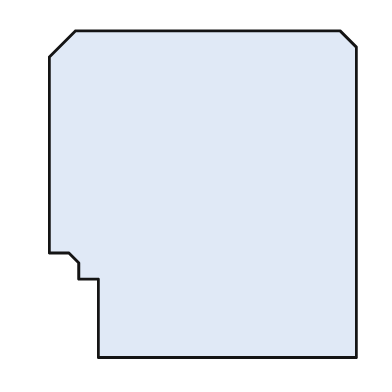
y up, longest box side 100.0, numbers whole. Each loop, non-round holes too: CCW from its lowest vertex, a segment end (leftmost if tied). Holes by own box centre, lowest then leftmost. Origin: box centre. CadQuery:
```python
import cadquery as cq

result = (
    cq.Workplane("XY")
    .moveTo(-32.0, -50.0)
    .lineTo(47.0, -50.0)
    .lineTo(47.0, 45.0)
    .lineTo(42.0, 50.0)
    .lineTo(-39.0, 50.0)
    .lineTo(-47.0, 42.0)
    .lineTo(-47.0, -18.0)
    .lineTo(-41.0, -18.0)
    .lineTo(-38.0, -21.0)
    .lineTo(-38.0, -26.0)
    .lineTo(-32.0, -26.0)
    .close()
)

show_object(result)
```